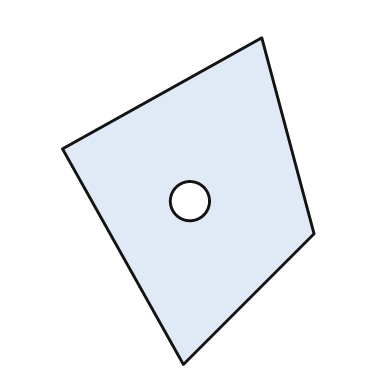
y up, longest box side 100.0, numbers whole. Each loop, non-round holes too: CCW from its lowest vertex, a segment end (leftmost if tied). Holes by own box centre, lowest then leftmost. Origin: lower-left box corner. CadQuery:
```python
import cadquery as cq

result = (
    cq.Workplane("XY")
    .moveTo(37.0, 0.0)
    .lineTo(77.0, 40.0)
    .lineTo(61.0, 100.0)
    .lineTo(0.0, 66.0)
    .close()
    .moveTo(39.0, 50.0)
    .circle(6.0)
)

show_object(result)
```